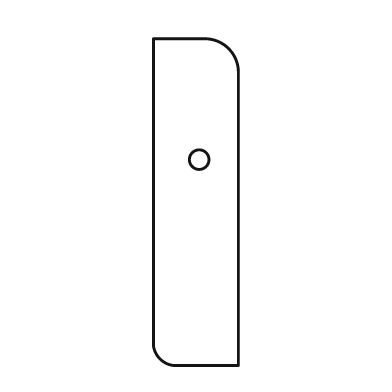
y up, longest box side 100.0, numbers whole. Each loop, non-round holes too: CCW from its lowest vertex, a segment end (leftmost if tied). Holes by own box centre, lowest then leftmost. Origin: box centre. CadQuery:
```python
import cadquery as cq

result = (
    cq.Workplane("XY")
    .moveTo(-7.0, -50.0)
    .lineTo(13.0, -50.0)
    .lineTo(13.0, 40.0)
    .threePointArc((10.0, 47.0), (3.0, 50.0))
    .lineTo(-13.0, 50.0)
    .lineTo(-13.0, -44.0)
    .threePointArc((-11.0, -48.0), (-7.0, -50.0))
    .close()
    .moveTo(1.0, 13.0)
    .circle(3.0)
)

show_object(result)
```